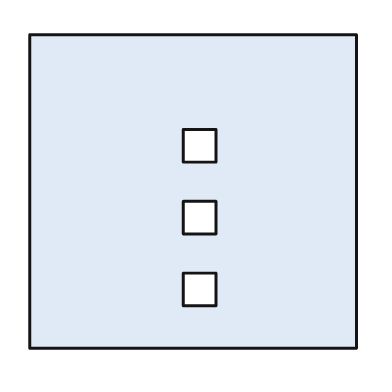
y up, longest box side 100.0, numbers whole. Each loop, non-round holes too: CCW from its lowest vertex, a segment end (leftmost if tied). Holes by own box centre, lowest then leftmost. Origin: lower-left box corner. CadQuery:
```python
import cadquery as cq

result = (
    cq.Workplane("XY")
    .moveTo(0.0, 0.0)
    .lineTo(100.0, 0.0)
    .lineTo(100.0, 96.0)
    .lineTo(0.0, 96.0)
    .close()
    .moveTo(47.0, 13.0)
    .lineTo(57.0, 13.0)
    .lineTo(57.0, 23.0)
    .lineTo(47.0, 23.0)
    .close()
    .moveTo(47.0, 35.0)
    .lineTo(57.0, 35.0)
    .lineTo(57.0, 45.0)
    .lineTo(47.0, 45.0)
    .close()
    .moveTo(47.0, 57.0)
    .lineTo(57.0, 57.0)
    .lineTo(57.0, 67.0)
    .lineTo(47.0, 67.0)
    .close()
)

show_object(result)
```